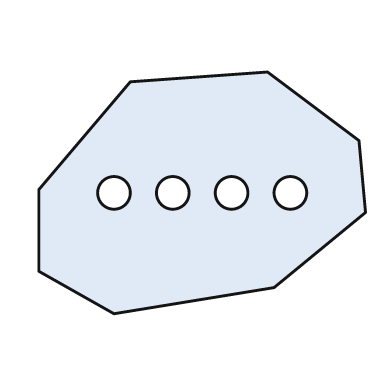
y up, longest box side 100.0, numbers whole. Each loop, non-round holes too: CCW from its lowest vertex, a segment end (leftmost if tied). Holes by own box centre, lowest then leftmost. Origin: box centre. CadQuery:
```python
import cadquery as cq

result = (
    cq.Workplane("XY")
    .moveTo(-27.0, -37.0)
    .lineTo(22.0, -29.0)
    .lineTo(50.0, -6.0)
    .lineTo(48.0, 16.0)
    .lineTo(20.0, 37.0)
    .lineTo(-22.0, 34.0)
    .lineTo(-50.0, 1.0)
    .lineTo(-50.0, -24.0)
    .close()
    .moveTo(-27.0, 0.0)
    .circle(5.0)
    .moveTo(-9.0, 0.0)
    .circle(5.0)
    .moveTo(9.0, 0.0)
    .circle(5.0)
    .moveTo(27.0, 0.0)
    .circle(5.0)
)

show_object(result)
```